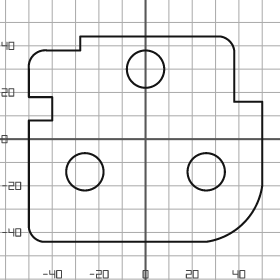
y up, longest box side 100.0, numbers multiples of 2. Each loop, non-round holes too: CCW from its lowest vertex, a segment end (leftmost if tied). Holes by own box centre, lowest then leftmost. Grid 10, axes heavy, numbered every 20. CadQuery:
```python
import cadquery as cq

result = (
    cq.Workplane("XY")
    .moveTo(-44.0, -44.0)
    .lineTo(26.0, -44.0)
    .threePointArc((42.0, -36.0), (50.0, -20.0))
    .lineTo(50.0, 16.0)
    .lineTo(38.0, 16.0)
    .lineTo(38.0, 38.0)
    .threePointArc((36.0, 42.0), (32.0, 44.0))
    .lineTo(-28.0, 44.0)
    .lineTo(-28.0, 38.0)
    .lineTo(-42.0, 38.0)
    .threePointArc((-48.0, 36.0), (-50.0, 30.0))
    .lineTo(-50.0, 18.0)
    .lineTo(-40.0, 18.0)
    .lineTo(-40.0, 8.0)
    .lineTo(-50.0, 8.0)
    .lineTo(-50.0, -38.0)
    .threePointArc((-48.0, -42.0), (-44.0, -44.0))
    .close()
    .moveTo(-26.0, -14.0)
    .circle(8.0)
    .moveTo(26.0, -14.0)
    .circle(8.0)
    .moveTo(0.0, 30.0)
    .circle(8.0)
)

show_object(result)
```